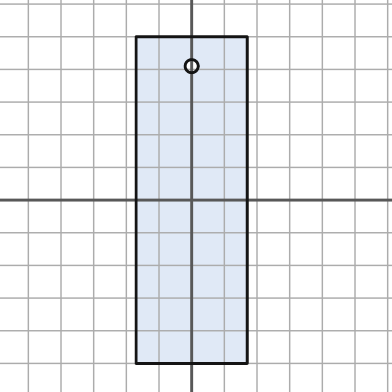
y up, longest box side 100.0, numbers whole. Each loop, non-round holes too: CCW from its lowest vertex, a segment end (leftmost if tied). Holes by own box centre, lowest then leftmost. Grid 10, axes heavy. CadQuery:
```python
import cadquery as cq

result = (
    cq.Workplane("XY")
    .moveTo(-17.0, -50.0)
    .lineTo(17.0, -50.0)
    .lineTo(17.0, 50.0)
    .lineTo(-17.0, 50.0)
    .close()
    .moveTo(0.0, 41.0)
    .circle(2.0)
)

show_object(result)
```